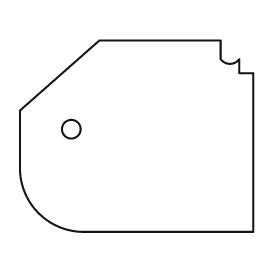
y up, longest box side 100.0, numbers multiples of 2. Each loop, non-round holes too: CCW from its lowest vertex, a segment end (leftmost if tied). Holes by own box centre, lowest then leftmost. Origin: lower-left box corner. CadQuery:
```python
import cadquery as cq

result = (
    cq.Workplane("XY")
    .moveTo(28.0, 0.0)
    .lineTo(100.0, 0.0)
    .lineTo(100.0, 68.0)
    .lineTo(94.0, 68.0)
    .lineTo(94.0, 74.0)
    .threePointArc((90.0, 72.0), (86.0, 74.0))
    .lineTo(86.0, 82.0)
    .lineTo(34.0, 82.0)
    .lineTo(0.0, 52.0)
    .lineTo(0.0, 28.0)
    .threePointArc((8.0, 8.0), (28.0, 0.0))
    .close()
    .moveTo(22.0, 44.0)
    .circle(4.0)
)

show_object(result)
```